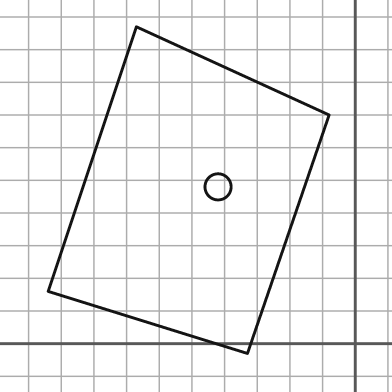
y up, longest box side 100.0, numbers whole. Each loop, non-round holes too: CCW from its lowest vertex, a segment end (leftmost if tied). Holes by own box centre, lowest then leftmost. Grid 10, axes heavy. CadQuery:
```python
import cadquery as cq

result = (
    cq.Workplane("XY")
    .moveTo(-33.0, -3.0)
    .lineTo(-8.0, 70.0)
    .lineTo(-67.0, 97.0)
    .lineTo(-94.0, 16.0)
    .close()
    .moveTo(-42.0, 48.0)
    .circle(4.0)
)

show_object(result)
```